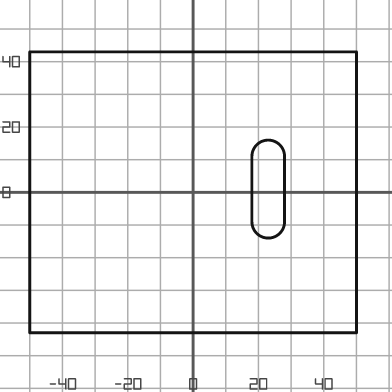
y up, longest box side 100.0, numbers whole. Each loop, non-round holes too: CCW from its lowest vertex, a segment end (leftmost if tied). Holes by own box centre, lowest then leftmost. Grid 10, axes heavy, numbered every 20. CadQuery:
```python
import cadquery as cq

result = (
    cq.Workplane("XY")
    .moveTo(-50.0, -43.0)
    .lineTo(50.0, -43.0)
    .lineTo(50.0, 43.0)
    .lineTo(-50.0, 43.0)
    .close()
    .moveTo(18.0, -9.0)
    .threePointArc((23.0, -14.0), (28.0, -9.0))
    .lineTo(28.0, 11.0)
    .threePointArc((23.0, 16.0), (18.0, 11.0))
    .close()
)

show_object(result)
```